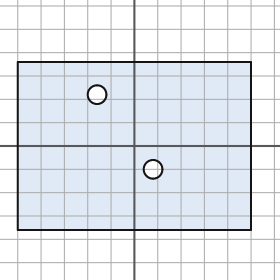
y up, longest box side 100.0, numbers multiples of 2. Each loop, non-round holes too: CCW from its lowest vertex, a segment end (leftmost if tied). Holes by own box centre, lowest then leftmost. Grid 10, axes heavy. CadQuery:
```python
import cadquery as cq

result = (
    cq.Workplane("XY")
    .moveTo(-50.0, -36.0)
    .lineTo(50.0, -36.0)
    .lineTo(50.0, 36.0)
    .lineTo(-50.0, 36.0)
    .close()
    .moveTo(8.0, -10.0)
    .circle(4.0)
    .moveTo(-16.0, 22.0)
    .circle(4.0)
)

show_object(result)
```